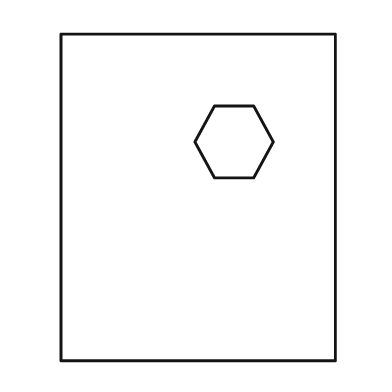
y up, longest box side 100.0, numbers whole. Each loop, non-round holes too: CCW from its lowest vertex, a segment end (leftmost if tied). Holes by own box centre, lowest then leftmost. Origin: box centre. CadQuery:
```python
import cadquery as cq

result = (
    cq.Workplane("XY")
    .moveTo(-42.0, -50.0)
    .lineTo(42.0, -50.0)
    .lineTo(42.0, 50.0)
    .lineTo(-42.0, 50.0)
    .close()
    .moveTo(5.0, 6.0)
    .lineTo(17.0, 6.0)
    .lineTo(23.0, 17.0)
    .lineTo(17.0, 28.0)
    .lineTo(5.0, 28.0)
    .lineTo(-1.0, 17.0)
    .close()
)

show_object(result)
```